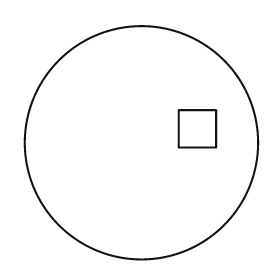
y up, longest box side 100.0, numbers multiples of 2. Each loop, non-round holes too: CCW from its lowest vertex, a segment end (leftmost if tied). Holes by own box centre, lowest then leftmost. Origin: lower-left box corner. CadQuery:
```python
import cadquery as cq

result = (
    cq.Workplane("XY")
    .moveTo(50.0, 50.0)
    .circle(50.0)
    .moveTo(66.0, 48.0)
    .lineTo(82.0, 48.0)
    .lineTo(82.0, 64.0)
    .lineTo(66.0, 64.0)
    .close()
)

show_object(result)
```